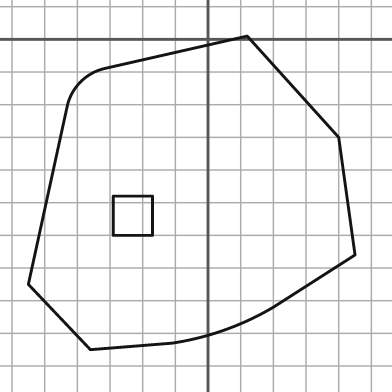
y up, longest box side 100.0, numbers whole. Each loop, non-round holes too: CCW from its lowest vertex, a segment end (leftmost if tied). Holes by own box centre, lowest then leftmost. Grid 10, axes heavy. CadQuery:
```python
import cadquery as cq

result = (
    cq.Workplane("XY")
    .moveTo(-36.0, -95.0)
    .lineTo(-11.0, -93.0)
    .threePointArc((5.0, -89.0), (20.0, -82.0))
    .lineTo(45.0, -66.0)
    .lineTo(40.0, -30.0)
    .lineTo(12.0, 1.0)
    .lineTo(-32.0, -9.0)
    .threePointArc((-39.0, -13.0), (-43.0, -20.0))
    .lineTo(-55.0, -75.0)
    .close()
    .moveTo(-29.0, -60.0)
    .lineTo(-17.0, -60.0)
    .lineTo(-17.0, -48.0)
    .lineTo(-29.0, -48.0)
    .close()
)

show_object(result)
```